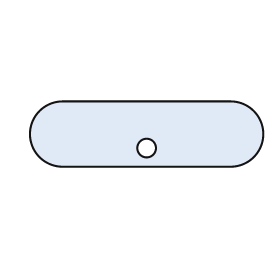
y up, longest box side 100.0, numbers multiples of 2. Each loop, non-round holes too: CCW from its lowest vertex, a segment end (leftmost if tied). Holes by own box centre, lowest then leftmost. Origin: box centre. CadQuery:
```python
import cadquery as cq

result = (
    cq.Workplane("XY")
    .moveTo(-36.0, -14.0)
    .lineTo(36.0, -14.0)
    .threePointArc((50.0, 0.0), (36.0, 14.0))
    .lineTo(-36.0, 14.0)
    .threePointArc((-50.0, 0.0), (-36.0, -14.0))
    .close()
    .moveTo(0.0, -6.0)
    .circle(4.0)
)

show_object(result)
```